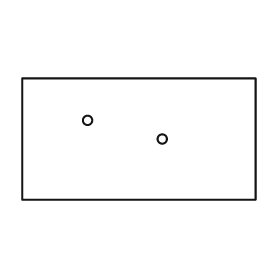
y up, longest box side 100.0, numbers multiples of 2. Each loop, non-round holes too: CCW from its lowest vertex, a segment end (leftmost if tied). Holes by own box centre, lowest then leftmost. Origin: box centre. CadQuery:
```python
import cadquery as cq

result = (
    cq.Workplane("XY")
    .moveTo(-50.0, -26.0)
    .lineTo(50.0, -26.0)
    .lineTo(50.0, 26.0)
    .lineTo(-50.0, 26.0)
    .close()
    .moveTo(10.0, 0.0)
    .circle(2.0)
    .moveTo(-22.0, 8.0)
    .circle(2.0)
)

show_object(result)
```